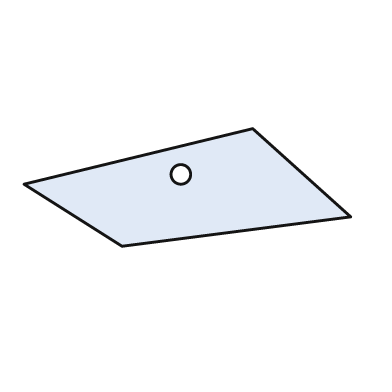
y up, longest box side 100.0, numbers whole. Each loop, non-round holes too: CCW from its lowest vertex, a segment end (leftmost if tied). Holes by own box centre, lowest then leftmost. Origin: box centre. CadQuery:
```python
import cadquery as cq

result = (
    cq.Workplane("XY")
    .moveTo(-20.0, -18.0)
    .lineTo(50.0, -9.0)
    .lineTo(20.0, 18.0)
    .lineTo(-50.0, 1.0)
    .close()
    .moveTo(-2.0, 4.0)
    .circle(3.0)
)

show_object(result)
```